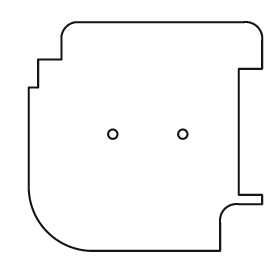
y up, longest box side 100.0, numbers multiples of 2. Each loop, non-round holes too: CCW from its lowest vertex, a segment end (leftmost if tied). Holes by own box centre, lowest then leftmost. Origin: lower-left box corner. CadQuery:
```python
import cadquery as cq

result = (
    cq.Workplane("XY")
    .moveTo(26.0, 0.0)
    .lineTo(82.0, 0.0)
    .lineTo(82.0, 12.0)
    .threePointArc((84.0, 18.0), (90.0, 20.0))
    .lineTo(100.0, 20.0)
    .lineTo(100.0, 24.0)
    .lineTo(90.0, 24.0)
    .lineTo(90.0, 78.0)
    .lineTo(100.0, 78.0)
    .lineTo(100.0, 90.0)
    .threePointArc((98.0, 96.0), (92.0, 98.0))
    .lineTo(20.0, 98.0)
    .threePointArc((16.0, 96.0), (14.0, 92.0))
    .lineTo(14.0, 82.0)
    .lineTo(4.0, 82.0)
    .lineTo(4.0, 70.0)
    .lineTo(0.0, 70.0)
    .lineTo(0.0, 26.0)
    .threePointArc((8.0, 8.0), (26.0, 0.0))
    .close()
    .moveTo(36.0, 50.0)
    .circle(2.0)
    .moveTo(66.0, 50.0)
    .circle(2.0)
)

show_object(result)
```